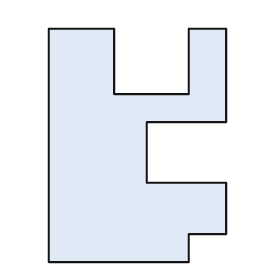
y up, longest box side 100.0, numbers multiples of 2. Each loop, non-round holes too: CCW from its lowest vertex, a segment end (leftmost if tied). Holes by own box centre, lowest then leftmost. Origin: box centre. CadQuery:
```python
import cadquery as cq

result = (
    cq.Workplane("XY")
    .moveTo(-38.0, -50.0)
    .lineTo(22.0, -50.0)
    .lineTo(22.0, -38.0)
    .lineTo(38.0, -38.0)
    .lineTo(38.0, -16.0)
    .lineTo(4.0, -16.0)
    .lineTo(4.0, 10.0)
    .lineTo(38.0, 10.0)
    .lineTo(38.0, 50.0)
    .lineTo(22.0, 50.0)
    .lineTo(22.0, 22.0)
    .lineTo(-10.0, 22.0)
    .lineTo(-10.0, 50.0)
    .lineTo(-38.0, 50.0)
    .close()
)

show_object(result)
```